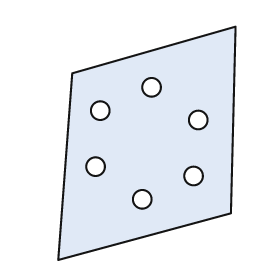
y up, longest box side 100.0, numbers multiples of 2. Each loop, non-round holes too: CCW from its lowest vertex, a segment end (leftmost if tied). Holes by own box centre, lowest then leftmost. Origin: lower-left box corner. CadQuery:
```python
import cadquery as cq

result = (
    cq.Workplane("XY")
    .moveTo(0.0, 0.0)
    .lineTo(74.0, 20.0)
    .lineTo(76.0, 100.0)
    .lineTo(6.0, 80.0)
    .close()
    .moveTo(36.0, 26.0)
    .circle(4.0)
    .moveTo(58.0, 36.0)
    .circle(4.0)
    .moveTo(16.0, 40.0)
    .circle(4.0)
    .moveTo(60.0, 60.0)
    .circle(4.0)
    .moveTo(18.0, 64.0)
    .circle(4.0)
    .moveTo(40.0, 74.0)
    .circle(4.0)
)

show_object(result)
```